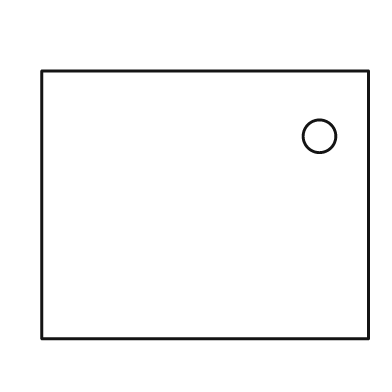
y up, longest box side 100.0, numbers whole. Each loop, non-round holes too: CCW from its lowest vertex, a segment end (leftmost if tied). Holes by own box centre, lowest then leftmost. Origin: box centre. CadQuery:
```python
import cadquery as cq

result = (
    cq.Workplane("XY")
    .moveTo(-50.0, -41.0)
    .lineTo(50.0, -41.0)
    .lineTo(50.0, 41.0)
    .lineTo(-50.0, 41.0)
    .close()
    .moveTo(35.0, 21.0)
    .circle(5.0)
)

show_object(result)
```